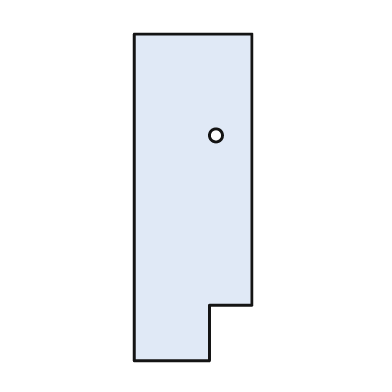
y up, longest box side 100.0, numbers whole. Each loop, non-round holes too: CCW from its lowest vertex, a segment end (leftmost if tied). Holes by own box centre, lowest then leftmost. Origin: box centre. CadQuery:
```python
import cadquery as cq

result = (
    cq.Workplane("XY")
    .moveTo(-18.0, -50.0)
    .lineTo(5.0, -50.0)
    .lineTo(5.0, -33.0)
    .lineTo(18.0, -33.0)
    .lineTo(18.0, 50.0)
    .lineTo(-18.0, 50.0)
    .close()
    .moveTo(7.0, 19.0)
    .circle(2.0)
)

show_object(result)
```